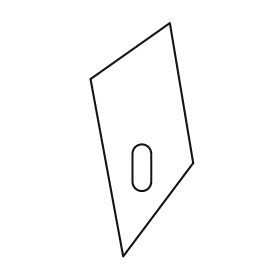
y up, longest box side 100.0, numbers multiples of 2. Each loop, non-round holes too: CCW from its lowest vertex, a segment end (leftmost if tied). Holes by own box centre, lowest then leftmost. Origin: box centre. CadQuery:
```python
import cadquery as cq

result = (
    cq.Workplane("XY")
    .moveTo(-8.0, -50.0)
    .lineTo(22.0, -10.0)
    .lineTo(12.0, 50.0)
    .lineTo(-22.0, 26.0)
    .close()
    .moveTo(-4.0, -18.0)
    .threePointArc((0.0, -22.0), (4.0, -18.0))
    .lineTo(4.0, -6.0)
    .threePointArc((0.0, -2.0), (-4.0, -6.0))
    .close()
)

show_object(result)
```